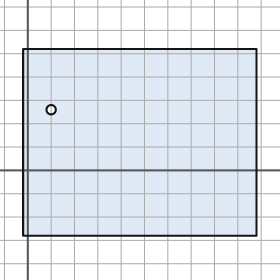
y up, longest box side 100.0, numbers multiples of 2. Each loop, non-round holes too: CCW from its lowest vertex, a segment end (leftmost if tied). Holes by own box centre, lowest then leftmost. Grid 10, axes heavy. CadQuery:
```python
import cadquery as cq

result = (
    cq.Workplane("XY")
    .moveTo(-2.0, -28.0)
    .lineTo(98.0, -28.0)
    .lineTo(98.0, 52.0)
    .lineTo(-2.0, 52.0)
    .close()
    .moveTo(10.0, 26.0)
    .circle(2.0)
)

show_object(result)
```